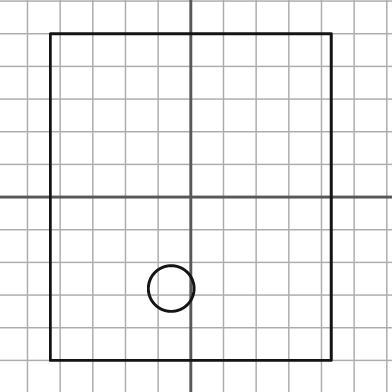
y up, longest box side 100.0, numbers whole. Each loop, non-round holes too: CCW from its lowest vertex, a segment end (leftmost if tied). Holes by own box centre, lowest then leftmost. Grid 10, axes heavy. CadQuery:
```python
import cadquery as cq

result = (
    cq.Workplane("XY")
    .moveTo(-43.0, -50.0)
    .lineTo(43.0, -50.0)
    .lineTo(43.0, 50.0)
    .lineTo(-43.0, 50.0)
    .close()
    .moveTo(-6.0, -28.0)
    .circle(7.0)
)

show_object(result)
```